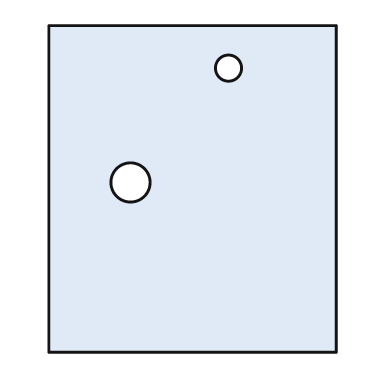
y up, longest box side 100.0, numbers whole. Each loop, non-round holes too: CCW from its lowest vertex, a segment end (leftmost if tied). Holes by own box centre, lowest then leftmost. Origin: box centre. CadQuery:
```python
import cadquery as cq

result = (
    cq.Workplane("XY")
    .moveTo(-44.0, -50.0)
    .lineTo(44.0, -50.0)
    .lineTo(44.0, 50.0)
    .lineTo(-44.0, 50.0)
    .close()
    .moveTo(-19.0, 2.0)
    .circle(6.0)
    .moveTo(11.0, 37.0)
    .circle(4.0)
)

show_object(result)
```